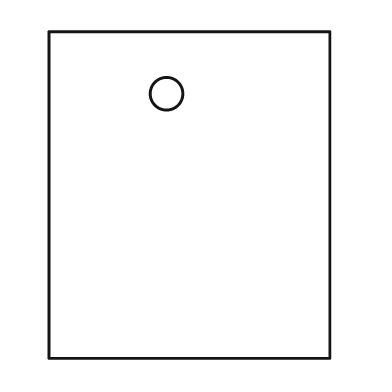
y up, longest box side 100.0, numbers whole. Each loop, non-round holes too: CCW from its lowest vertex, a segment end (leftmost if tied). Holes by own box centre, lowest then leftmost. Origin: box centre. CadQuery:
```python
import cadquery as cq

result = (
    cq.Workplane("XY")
    .moveTo(-43.0, -50.0)
    .lineTo(43.0, -50.0)
    .lineTo(43.0, 50.0)
    .lineTo(-43.0, 50.0)
    .close()
    .moveTo(-7.0, 31.0)
    .circle(5.0)
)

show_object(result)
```